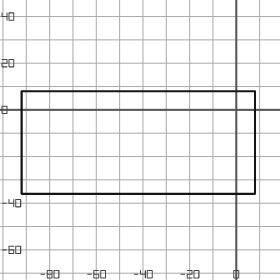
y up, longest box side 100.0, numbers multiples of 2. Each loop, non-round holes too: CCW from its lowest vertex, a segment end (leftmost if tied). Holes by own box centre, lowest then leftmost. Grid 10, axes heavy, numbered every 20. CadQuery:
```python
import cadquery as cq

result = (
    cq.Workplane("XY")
    .moveTo(-92.0, -36.0)
    .lineTo(8.0, -36.0)
    .lineTo(8.0, 8.0)
    .lineTo(-92.0, 8.0)
    .close()
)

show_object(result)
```